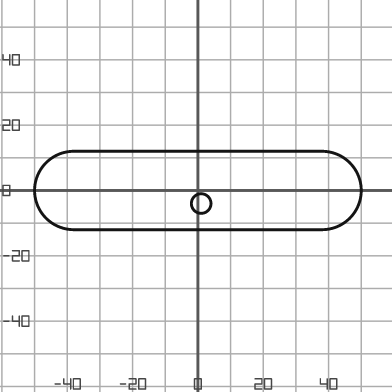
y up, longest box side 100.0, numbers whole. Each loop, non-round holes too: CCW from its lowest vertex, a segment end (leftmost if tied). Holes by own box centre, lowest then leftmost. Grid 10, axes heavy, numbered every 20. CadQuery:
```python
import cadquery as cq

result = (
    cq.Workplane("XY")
    .moveTo(-38.0, -12.0)
    .lineTo(38.0, -12.0)
    .threePointArc((50.0, 0.0), (38.0, 12.0))
    .lineTo(-38.0, 12.0)
    .threePointArc((-50.0, 0.0), (-38.0, -12.0))
    .close()
    .moveTo(1.0, -4.0)
    .circle(3.0)
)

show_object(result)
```